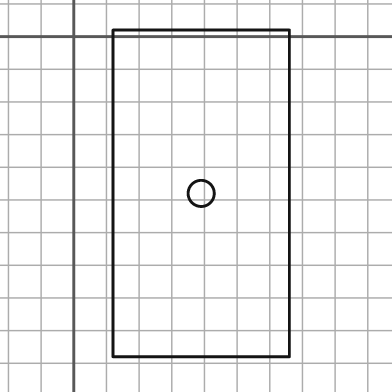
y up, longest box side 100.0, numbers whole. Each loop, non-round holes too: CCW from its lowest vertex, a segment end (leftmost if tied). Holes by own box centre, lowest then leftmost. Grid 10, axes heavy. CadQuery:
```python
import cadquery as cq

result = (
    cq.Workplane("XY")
    .moveTo(12.0, -98.0)
    .lineTo(66.0, -98.0)
    .lineTo(66.0, 2.0)
    .lineTo(12.0, 2.0)
    .close()
    .moveTo(39.0, -48.0)
    .circle(4.0)
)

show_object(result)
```